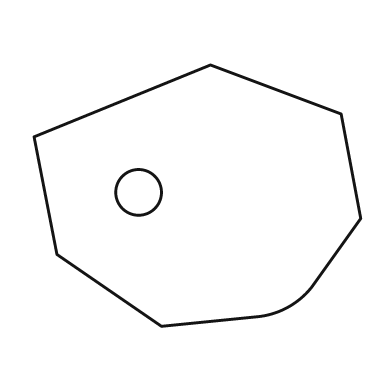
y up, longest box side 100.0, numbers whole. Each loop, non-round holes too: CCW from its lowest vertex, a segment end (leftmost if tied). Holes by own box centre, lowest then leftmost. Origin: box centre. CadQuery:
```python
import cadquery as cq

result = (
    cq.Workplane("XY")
    .moveTo(-11.0, -40.0)
    .lineTo(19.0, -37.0)
    .threePointArc((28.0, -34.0), (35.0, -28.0))
    .lineTo(50.0, -7.0)
    .lineTo(44.0, 25.0)
    .lineTo(4.0, 40.0)
    .lineTo(-50.0, 18.0)
    .lineTo(-43.0, -18.0)
    .close()
    .moveTo(-18.0, 1.0)
    .circle(7.0)
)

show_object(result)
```